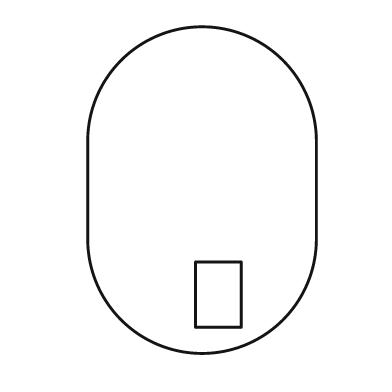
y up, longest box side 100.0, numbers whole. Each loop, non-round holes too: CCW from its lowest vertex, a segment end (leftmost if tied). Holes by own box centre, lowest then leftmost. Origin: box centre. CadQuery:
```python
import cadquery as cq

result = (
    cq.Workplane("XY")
    .moveTo(-35.0, -15.0)
    .threePointArc((0.0, -50.0), (35.0, -15.0))
    .lineTo(35.0, 15.0)
    .threePointArc((0.0, 50.0), (-35.0, 15.0))
    .close()
    .moveTo(-2.0, -42.0)
    .lineTo(12.0, -42.0)
    .lineTo(12.0, -22.0)
    .lineTo(-2.0, -22.0)
    .close()
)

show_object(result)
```